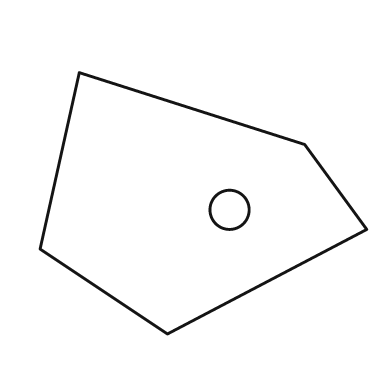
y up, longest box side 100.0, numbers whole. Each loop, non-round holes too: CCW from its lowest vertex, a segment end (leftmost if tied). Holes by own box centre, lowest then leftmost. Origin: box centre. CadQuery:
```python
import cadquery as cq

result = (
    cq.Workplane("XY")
    .moveTo(-11.0, -40.0)
    .lineTo(50.0, -8.0)
    .lineTo(31.0, 18.0)
    .lineTo(-38.0, 40.0)
    .lineTo(-50.0, -14.0)
    .close()
    .moveTo(8.0, -2.0)
    .circle(6.0)
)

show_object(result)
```